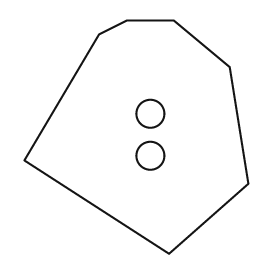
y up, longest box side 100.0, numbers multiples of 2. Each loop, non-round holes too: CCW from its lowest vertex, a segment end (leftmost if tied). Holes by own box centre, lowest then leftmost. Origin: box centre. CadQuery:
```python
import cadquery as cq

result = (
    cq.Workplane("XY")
    .moveTo(14.0, -50.0)
    .lineTo(48.0, -20.0)
    .lineTo(40.0, 30.0)
    .lineTo(16.0, 50.0)
    .lineTo(-4.0, 50.0)
    .lineTo(-16.0, 44.0)
    .lineTo(-48.0, -10.0)
    .close()
    .moveTo(6.0, -8.0)
    .circle(6.0)
    .moveTo(6.0, 10.0)
    .circle(6.0)
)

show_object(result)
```